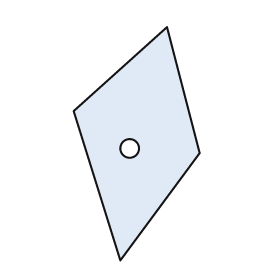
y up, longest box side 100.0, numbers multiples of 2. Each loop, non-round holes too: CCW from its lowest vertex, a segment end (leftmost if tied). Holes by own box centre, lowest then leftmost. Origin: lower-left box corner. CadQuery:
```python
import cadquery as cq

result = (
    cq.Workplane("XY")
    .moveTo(20.0, 0.0)
    .lineTo(54.0, 46.0)
    .lineTo(40.0, 100.0)
    .lineTo(0.0, 64.0)
    .close()
    .moveTo(24.0, 48.0)
    .circle(4.0)
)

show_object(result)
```